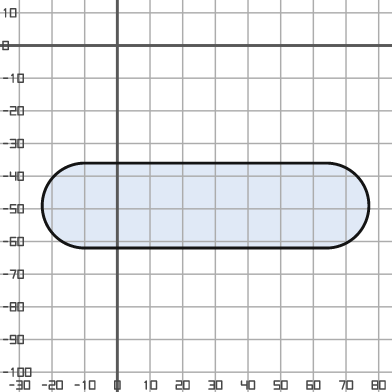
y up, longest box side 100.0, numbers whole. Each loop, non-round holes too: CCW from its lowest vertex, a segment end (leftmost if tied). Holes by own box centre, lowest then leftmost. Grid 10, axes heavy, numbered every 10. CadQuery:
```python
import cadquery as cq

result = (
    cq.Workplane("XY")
    .moveTo(-10.0, -62.0)
    .lineTo(64.0, -62.0)
    .threePointArc((77.0, -49.0), (64.0, -36.0))
    .lineTo(-10.0, -36.0)
    .threePointArc((-23.0, -49.0), (-10.0, -62.0))
    .close()
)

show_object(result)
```